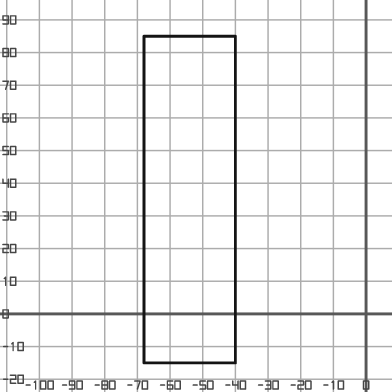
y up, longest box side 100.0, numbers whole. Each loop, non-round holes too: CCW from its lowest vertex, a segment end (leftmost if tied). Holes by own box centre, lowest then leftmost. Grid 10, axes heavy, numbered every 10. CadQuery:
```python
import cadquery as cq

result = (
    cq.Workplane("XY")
    .moveTo(-68.0, -15.0)
    .lineTo(-40.0, -15.0)
    .lineTo(-40.0, 85.0)
    .lineTo(-68.0, 85.0)
    .close()
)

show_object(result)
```